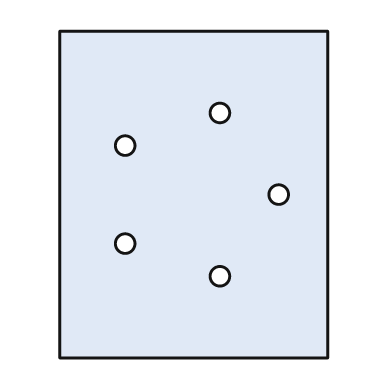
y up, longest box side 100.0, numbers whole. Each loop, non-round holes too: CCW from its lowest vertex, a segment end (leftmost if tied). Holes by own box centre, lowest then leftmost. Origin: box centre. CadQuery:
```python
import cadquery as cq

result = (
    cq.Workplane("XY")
    .moveTo(-41.0, -50.0)
    .lineTo(41.0, -50.0)
    .lineTo(41.0, 50.0)
    .lineTo(-41.0, 50.0)
    .close()
    .moveTo(8.0, -25.0)
    .circle(3.0)
    .moveTo(-21.0, -15.0)
    .circle(3.0)
    .moveTo(26.0, 0.0)
    .circle(3.0)
    .moveTo(-21.0, 15.0)
    .circle(3.0)
    .moveTo(8.0, 25.0)
    .circle(3.0)
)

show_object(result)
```